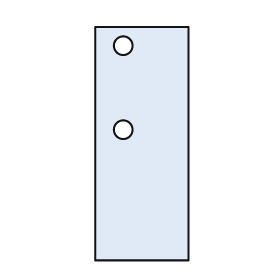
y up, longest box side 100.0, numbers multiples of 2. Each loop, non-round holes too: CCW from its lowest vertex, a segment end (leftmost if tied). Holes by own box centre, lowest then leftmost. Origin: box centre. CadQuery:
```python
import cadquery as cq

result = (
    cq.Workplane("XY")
    .moveTo(-20.0, -50.0)
    .lineTo(20.0, -50.0)
    .lineTo(20.0, 50.0)
    .lineTo(-20.0, 50.0)
    .close()
    .moveTo(-8.0, 6.0)
    .circle(4.0)
    .moveTo(-8.0, 42.0)
    .circle(4.0)
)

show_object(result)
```